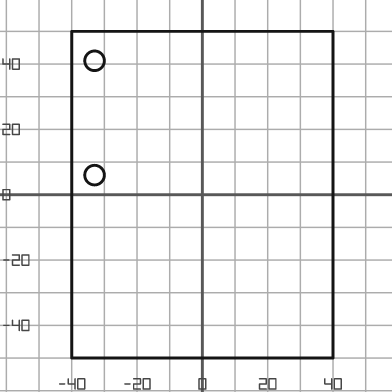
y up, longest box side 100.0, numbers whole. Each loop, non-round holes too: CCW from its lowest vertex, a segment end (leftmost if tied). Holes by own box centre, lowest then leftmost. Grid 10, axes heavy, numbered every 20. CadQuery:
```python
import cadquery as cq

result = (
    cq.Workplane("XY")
    .moveTo(-40.0, -50.0)
    .lineTo(40.0, -50.0)
    .lineTo(40.0, 50.0)
    .lineTo(-40.0, 50.0)
    .close()
    .moveTo(-33.0, 6.0)
    .circle(3.0)
    .moveTo(-33.0, 41.0)
    .circle(3.0)
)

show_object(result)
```